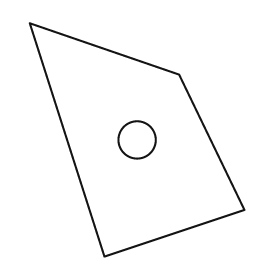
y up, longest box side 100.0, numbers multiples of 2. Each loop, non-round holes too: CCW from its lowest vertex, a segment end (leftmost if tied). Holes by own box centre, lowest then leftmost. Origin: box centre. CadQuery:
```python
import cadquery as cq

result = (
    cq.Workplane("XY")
    .moveTo(-14.0, -50.0)
    .lineTo(46.0, -30.0)
    .lineTo(18.0, 28.0)
    .lineTo(-46.0, 50.0)
    .close()
    .moveTo(0.0, 0.0)
    .circle(8.0)
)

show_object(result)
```